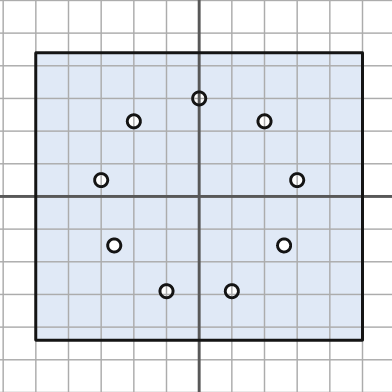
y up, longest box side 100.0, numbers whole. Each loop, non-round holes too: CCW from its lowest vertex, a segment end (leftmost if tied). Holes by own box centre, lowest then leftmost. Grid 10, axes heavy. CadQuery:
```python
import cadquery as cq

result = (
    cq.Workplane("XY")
    .moveTo(-50.0, -44.0)
    .lineTo(50.0, -44.0)
    .lineTo(50.0, 44.0)
    .lineTo(-50.0, 44.0)
    .close()
    .moveTo(-10.0, -29.0)
    .circle(2.0)
    .moveTo(10.0, -29.0)
    .circle(2.0)
    .moveTo(-26.0, -15.0)
    .circle(2.0)
    .moveTo(26.0, -15.0)
    .circle(2.0)
    .moveTo(-30.0, 5.0)
    .circle(2.0)
    .moveTo(30.0, 5.0)
    .circle(2.0)
    .moveTo(-20.0, 23.0)
    .circle(2.0)
    .moveTo(20.0, 23.0)
    .circle(2.0)
    .moveTo(0.0, 30.0)
    .circle(2.0)
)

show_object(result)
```